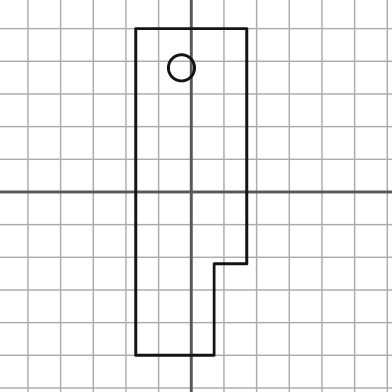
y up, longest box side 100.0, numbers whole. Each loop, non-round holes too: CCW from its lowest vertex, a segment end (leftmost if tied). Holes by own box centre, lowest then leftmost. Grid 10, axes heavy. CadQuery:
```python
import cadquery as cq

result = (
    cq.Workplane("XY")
    .moveTo(-17.0, -50.0)
    .lineTo(7.0, -50.0)
    .lineTo(7.0, -22.0)
    .lineTo(17.0, -22.0)
    .lineTo(17.0, 50.0)
    .lineTo(-17.0, 50.0)
    .close()
    .moveTo(-3.0, 38.0)
    .circle(4.0)
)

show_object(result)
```